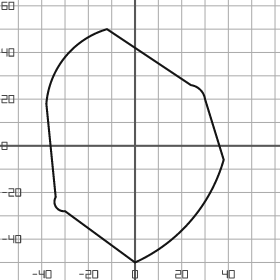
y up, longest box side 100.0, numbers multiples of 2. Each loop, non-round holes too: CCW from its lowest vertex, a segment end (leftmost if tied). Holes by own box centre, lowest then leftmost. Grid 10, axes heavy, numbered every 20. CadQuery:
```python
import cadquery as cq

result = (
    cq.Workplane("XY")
    .moveTo(0.0, -50.0)
    .threePointArc((24.0, -32.0), (38.0, -6.0))
    .lineTo(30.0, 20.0)
    .threePointArc((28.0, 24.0), (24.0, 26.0))
    .lineTo(-12.0, 50.0)
    .threePointArc((-30.0, 38.0), (-38.0, 18.0))
    .lineTo(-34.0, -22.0)
    .threePointArc((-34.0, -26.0), (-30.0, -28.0))
    .close()
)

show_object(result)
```